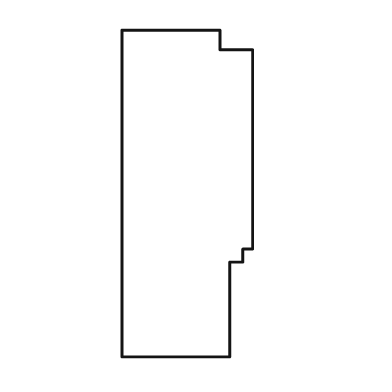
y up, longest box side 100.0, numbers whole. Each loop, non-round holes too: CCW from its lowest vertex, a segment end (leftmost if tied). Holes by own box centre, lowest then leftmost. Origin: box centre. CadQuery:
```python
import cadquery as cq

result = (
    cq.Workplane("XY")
    .moveTo(-20.0, -50.0)
    .lineTo(13.0, -50.0)
    .lineTo(13.0, -21.0)
    .lineTo(17.0, -21.0)
    .lineTo(17.0, -17.0)
    .lineTo(20.0, -17.0)
    .lineTo(20.0, 44.0)
    .lineTo(10.0, 44.0)
    .lineTo(10.0, 50.0)
    .lineTo(-20.0, 50.0)
    .close()
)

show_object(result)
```